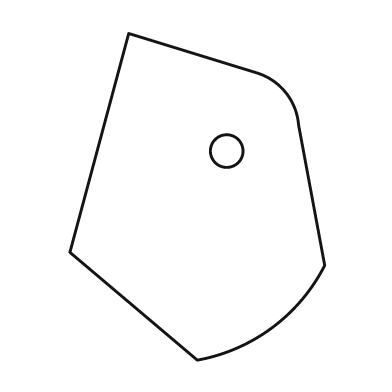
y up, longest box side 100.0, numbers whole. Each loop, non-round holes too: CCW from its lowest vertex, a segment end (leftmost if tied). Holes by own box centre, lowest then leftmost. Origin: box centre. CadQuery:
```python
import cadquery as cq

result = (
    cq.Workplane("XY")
    .moveTo(0.0, -50.0)
    .threePointArc((23.0, -40.0), (39.0, -21.0))
    .lineTo(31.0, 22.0)
    .threePointArc((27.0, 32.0), (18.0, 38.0))
    .lineTo(-21.0, 50.0)
    .lineTo(-39.0, -17.0)
    .close()
    .moveTo(9.0, 14.0)
    .circle(5.0)
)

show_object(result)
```